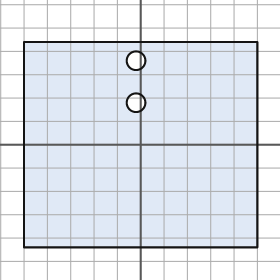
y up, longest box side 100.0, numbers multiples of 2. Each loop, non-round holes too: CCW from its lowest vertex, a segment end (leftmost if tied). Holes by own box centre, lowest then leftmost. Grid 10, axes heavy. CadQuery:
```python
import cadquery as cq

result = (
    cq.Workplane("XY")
    .moveTo(-50.0, -44.0)
    .lineTo(50.0, -44.0)
    .lineTo(50.0, 44.0)
    .lineTo(-50.0, 44.0)
    .close()
    .moveTo(-2.0, 18.0)
    .circle(4.0)
    .moveTo(-2.0, 36.0)
    .circle(4.0)
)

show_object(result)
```